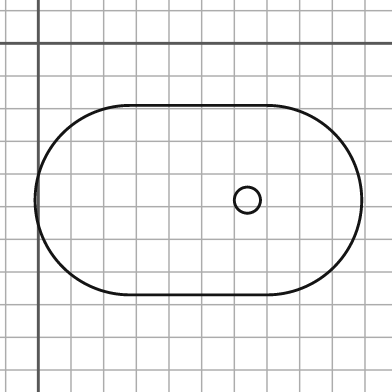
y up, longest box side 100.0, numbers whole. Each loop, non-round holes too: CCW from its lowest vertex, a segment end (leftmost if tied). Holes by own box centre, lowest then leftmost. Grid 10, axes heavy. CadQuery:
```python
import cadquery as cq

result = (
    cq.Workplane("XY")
    .moveTo(28.0, -77.0)
    .lineTo(70.0, -77.0)
    .threePointArc((99.0, -48.0), (70.0, -19.0))
    .lineTo(28.0, -19.0)
    .threePointArc((-1.0, -48.0), (28.0, -77.0))
    .close()
    .moveTo(64.0, -48.0)
    .circle(4.0)
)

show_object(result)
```